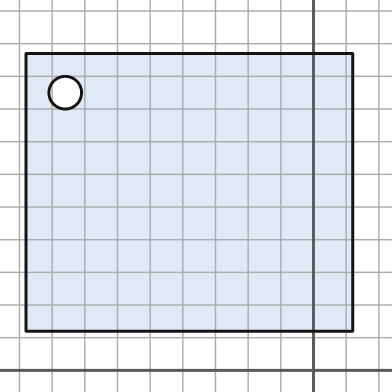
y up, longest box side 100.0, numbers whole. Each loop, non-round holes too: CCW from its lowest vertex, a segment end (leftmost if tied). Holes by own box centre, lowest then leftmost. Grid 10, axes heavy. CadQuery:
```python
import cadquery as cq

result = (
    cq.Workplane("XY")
    .moveTo(-88.0, 12.0)
    .lineTo(12.0, 12.0)
    .lineTo(12.0, 97.0)
    .lineTo(-88.0, 97.0)
    .close()
    .moveTo(-76.0, 85.0)
    .circle(5.0)
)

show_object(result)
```